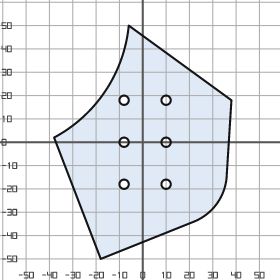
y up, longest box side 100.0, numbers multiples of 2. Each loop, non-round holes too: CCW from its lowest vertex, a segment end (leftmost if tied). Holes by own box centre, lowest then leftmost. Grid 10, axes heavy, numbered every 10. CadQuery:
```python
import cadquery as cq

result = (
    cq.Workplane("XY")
    .moveTo(-18.0, -50.0)
    .lineTo(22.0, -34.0)
    .threePointArc((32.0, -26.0), (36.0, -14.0))
    .lineTo(38.0, 18.0)
    .lineTo(-6.0, 50.0)
    .threePointArc((-16.0, 22.0), (-38.0, 2.0))
    .close()
    .moveTo(-8.0, -18.0)
    .circle(2.0)
    .moveTo(10.0, -18.0)
    .circle(2.0)
    .moveTo(-8.0, 0.0)
    .circle(2.0)
    .moveTo(10.0, 0.0)
    .circle(2.0)
    .moveTo(-8.0, 18.0)
    .circle(2.0)
    .moveTo(10.0, 18.0)
    .circle(2.0)
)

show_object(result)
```